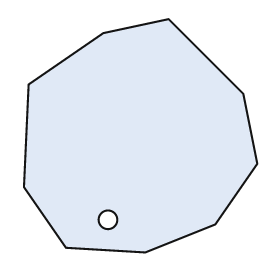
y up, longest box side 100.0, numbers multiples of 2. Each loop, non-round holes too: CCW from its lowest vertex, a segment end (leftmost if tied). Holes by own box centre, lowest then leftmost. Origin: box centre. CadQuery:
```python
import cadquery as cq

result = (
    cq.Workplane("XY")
    .moveTo(2.0, -50.0)
    .lineTo(32.0, -38.0)
    .lineTo(50.0, -12.0)
    .lineTo(44.0, 18.0)
    .lineTo(12.0, 50.0)
    .lineTo(-16.0, 44.0)
    .lineTo(-48.0, 22.0)
    .lineTo(-50.0, -22.0)
    .lineTo(-32.0, -48.0)
    .close()
    .moveTo(-14.0, -36.0)
    .circle(4.0)
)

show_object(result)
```